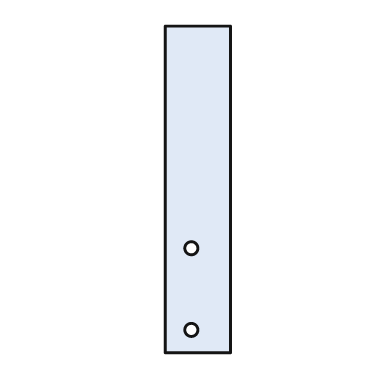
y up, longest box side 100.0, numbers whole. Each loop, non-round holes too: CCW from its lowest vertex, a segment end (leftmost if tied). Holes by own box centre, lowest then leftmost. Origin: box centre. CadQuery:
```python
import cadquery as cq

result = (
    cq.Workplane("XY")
    .moveTo(-10.0, -50.0)
    .lineTo(10.0, -50.0)
    .lineTo(10.0, 50.0)
    .lineTo(-10.0, 50.0)
    .close()
    .moveTo(-2.0, -43.0)
    .circle(2.0)
    .moveTo(-2.0, -18.0)
    .circle(2.0)
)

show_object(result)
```